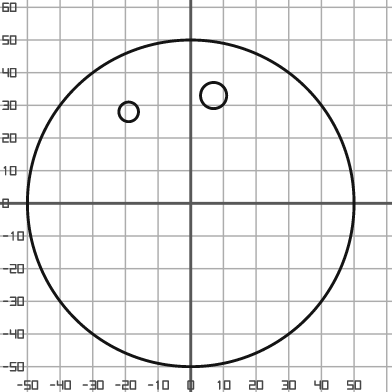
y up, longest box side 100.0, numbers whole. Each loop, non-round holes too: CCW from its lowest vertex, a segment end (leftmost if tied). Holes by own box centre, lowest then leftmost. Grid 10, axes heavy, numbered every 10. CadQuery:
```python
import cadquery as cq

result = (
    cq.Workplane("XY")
    .moveTo(0.0, 0.0)
    .circle(50.0)
    .moveTo(-19.0, 28.0)
    .circle(3.0)
    .moveTo(7.0, 33.0)
    .circle(4.0)
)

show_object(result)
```